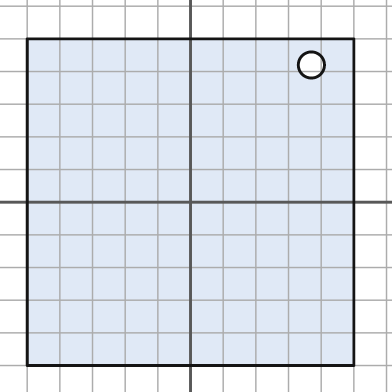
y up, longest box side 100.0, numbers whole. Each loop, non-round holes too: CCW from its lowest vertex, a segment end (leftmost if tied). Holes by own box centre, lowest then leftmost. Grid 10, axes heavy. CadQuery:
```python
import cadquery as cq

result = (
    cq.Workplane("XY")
    .moveTo(-50.0, -50.0)
    .lineTo(50.0, -50.0)
    .lineTo(50.0, 50.0)
    .lineTo(-50.0, 50.0)
    .close()
    .moveTo(37.0, 42.0)
    .circle(4.0)
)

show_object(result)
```